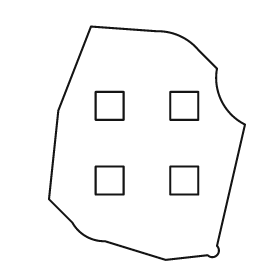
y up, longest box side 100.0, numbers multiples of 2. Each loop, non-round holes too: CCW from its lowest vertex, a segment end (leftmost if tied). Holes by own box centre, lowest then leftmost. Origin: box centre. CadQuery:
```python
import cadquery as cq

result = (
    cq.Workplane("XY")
    .moveTo(8.0, -50.0)
    .lineTo(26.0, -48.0)
    .threePointArc((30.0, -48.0), (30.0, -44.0))
    .lineTo(42.0, 8.0)
    .threePointArc((32.0, 18.0), (30.0, 32.0))
    .lineTo(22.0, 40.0)
    .threePointArc((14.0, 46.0), (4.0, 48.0))
    .lineTo(-24.0, 50.0)
    .lineTo(-38.0, 14.0)
    .lineTo(-42.0, -24.0)
    .lineTo(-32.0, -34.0)
    .threePointArc((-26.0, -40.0), (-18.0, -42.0))
    .close()
    .moveTo(-22.0, -22.0)
    .lineTo(-10.0, -22.0)
    .lineTo(-10.0, -10.0)
    .lineTo(-22.0, -10.0)
    .close()
    .moveTo(10.0, -22.0)
    .lineTo(22.0, -22.0)
    .lineTo(22.0, -10.0)
    .lineTo(10.0, -10.0)
    .close()
    .moveTo(-22.0, 10.0)
    .lineTo(-10.0, 10.0)
    .lineTo(-10.0, 22.0)
    .lineTo(-22.0, 22.0)
    .close()
    .moveTo(10.0, 10.0)
    .lineTo(22.0, 10.0)
    .lineTo(22.0, 22.0)
    .lineTo(10.0, 22.0)
    .close()
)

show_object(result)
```